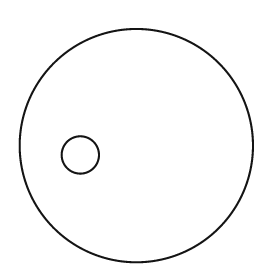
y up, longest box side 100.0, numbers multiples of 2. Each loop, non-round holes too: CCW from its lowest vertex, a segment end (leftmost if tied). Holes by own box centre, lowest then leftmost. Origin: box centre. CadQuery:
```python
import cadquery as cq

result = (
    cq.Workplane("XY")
    .moveTo(0.0, 0.0)
    .circle(50.0)
    .moveTo(-24.0, -4.0)
    .circle(8.0)
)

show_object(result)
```